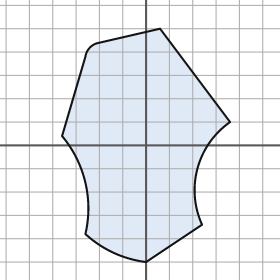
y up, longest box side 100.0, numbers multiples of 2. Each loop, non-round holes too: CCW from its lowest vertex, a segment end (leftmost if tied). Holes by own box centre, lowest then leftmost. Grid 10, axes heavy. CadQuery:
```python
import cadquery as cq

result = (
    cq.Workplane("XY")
    .moveTo(0.0, -50.0)
    .lineTo(24.0, -34.0)
    .threePointArc((22.0, -10.0), (36.0, 10.0))
    .lineTo(6.0, 50.0)
    .lineTo(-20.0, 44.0)
    .threePointArc((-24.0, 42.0), (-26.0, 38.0))
    .lineTo(-36.0, 4.0)
    .threePointArc((-26.0, -16.0), (-26.0, -38.0))
    .threePointArc((-14.0, -46.0), (0.0, -50.0))
    .close()
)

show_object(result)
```